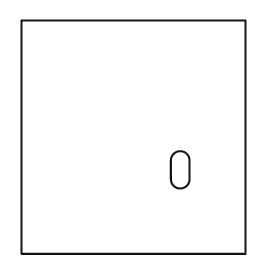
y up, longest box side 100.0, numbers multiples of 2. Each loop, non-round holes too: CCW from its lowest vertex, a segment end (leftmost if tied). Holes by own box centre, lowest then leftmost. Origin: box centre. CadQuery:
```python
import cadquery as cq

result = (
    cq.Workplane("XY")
    .moveTo(-48.0, -50.0)
    .lineTo(48.0, -50.0)
    .lineTo(48.0, 50.0)
    .lineTo(-48.0, 50.0)
    .close()
    .moveTo(16.0, -18.0)
    .threePointArc((20.0, -22.0), (24.0, -18.0))
    .lineTo(24.0, -10.0)
    .threePointArc((20.0, -6.0), (16.0, -10.0))
    .close()
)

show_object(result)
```